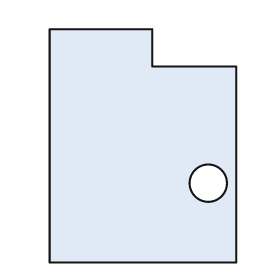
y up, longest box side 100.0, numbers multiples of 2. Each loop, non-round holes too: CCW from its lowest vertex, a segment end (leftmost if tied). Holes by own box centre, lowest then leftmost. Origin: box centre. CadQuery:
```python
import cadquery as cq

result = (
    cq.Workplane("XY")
    .moveTo(-40.0, -50.0)
    .lineTo(40.0, -50.0)
    .lineTo(40.0, 34.0)
    .lineTo(4.0, 34.0)
    .lineTo(4.0, 50.0)
    .lineTo(-40.0, 50.0)
    .close()
    .moveTo(28.0, -16.0)
    .circle(8.0)
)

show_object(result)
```